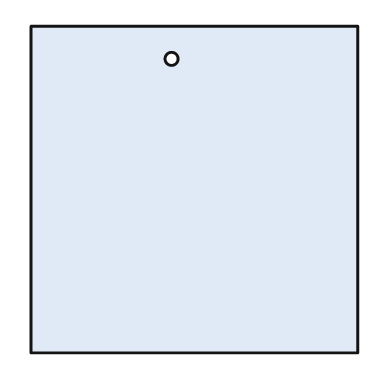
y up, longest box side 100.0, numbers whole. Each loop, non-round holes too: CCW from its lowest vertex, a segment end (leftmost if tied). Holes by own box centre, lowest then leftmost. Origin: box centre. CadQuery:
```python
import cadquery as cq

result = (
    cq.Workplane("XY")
    .moveTo(-50.0, -50.0)
    .lineTo(50.0, -50.0)
    .lineTo(50.0, 50.0)
    .lineTo(-50.0, 50.0)
    .close()
    .moveTo(-7.0, 40.0)
    .circle(2.0)
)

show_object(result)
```